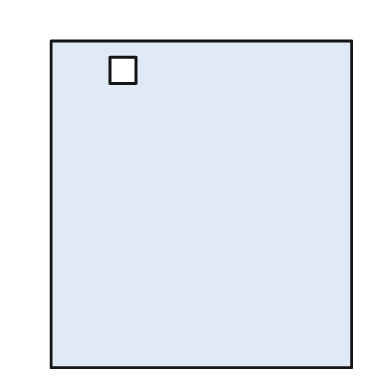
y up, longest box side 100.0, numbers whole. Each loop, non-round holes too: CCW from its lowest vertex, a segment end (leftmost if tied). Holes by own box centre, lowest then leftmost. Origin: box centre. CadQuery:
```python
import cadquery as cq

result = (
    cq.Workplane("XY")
    .moveTo(-46.0, -50.0)
    .lineTo(46.0, -50.0)
    .lineTo(46.0, 50.0)
    .lineTo(-46.0, 50.0)
    .close()
    .moveTo(-28.0, 37.0)
    .lineTo(-20.0, 37.0)
    .lineTo(-20.0, 45.0)
    .lineTo(-28.0, 45.0)
    .close()
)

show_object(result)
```